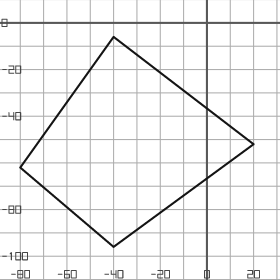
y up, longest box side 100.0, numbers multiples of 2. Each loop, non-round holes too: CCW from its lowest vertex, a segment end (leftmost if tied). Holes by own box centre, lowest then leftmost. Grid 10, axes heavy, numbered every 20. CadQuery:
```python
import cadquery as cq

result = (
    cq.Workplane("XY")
    .moveTo(-40.0, -96.0)
    .lineTo(20.0, -52.0)
    .lineTo(-40.0, -6.0)
    .lineTo(-80.0, -62.0)
    .close()
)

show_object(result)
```